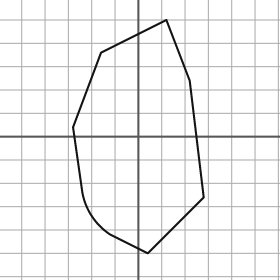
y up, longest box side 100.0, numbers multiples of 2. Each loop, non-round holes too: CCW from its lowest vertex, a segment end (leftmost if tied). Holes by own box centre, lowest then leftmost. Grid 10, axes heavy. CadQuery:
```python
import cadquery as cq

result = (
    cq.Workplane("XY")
    .moveTo(4.0, -50.0)
    .lineTo(28.0, -26.0)
    .lineTo(22.0, 24.0)
    .lineTo(12.0, 50.0)
    .lineTo(-16.0, 36.0)
    .lineTo(-28.0, 4.0)
    .lineTo(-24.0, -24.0)
    .threePointArc((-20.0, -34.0), (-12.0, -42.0))
    .close()
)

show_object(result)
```